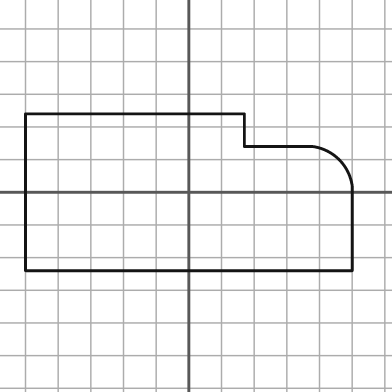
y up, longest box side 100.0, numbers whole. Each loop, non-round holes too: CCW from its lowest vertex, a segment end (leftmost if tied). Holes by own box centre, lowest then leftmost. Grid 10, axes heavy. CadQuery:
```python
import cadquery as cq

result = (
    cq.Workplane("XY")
    .moveTo(-50.0, -24.0)
    .lineTo(50.0, -24.0)
    .lineTo(50.0, 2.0)
    .threePointArc((46.0, 10.0), (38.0, 14.0))
    .lineTo(17.0, 14.0)
    .lineTo(17.0, 24.0)
    .lineTo(-50.0, 24.0)
    .close()
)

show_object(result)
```